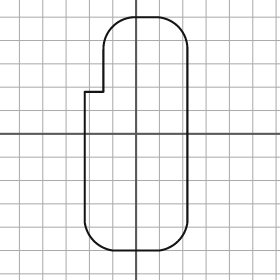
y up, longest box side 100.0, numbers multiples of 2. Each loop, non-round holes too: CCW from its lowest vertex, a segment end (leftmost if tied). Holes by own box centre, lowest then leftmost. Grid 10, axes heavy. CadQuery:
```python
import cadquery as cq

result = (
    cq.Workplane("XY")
    .moveTo(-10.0, -50.0)
    .lineTo(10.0, -50.0)
    .threePointArc((18.0, -46.0), (22.0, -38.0))
    .lineTo(22.0, 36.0)
    .threePointArc((18.0, 46.0), (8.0, 50.0))
    .lineTo(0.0, 50.0)
    .threePointArc((-10.0, 46.0), (-14.0, 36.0))
    .lineTo(-14.0, 18.0)
    .lineTo(-22.0, 18.0)
    .lineTo(-22.0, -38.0)
    .threePointArc((-18.0, -46.0), (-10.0, -50.0))
    .close()
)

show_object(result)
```